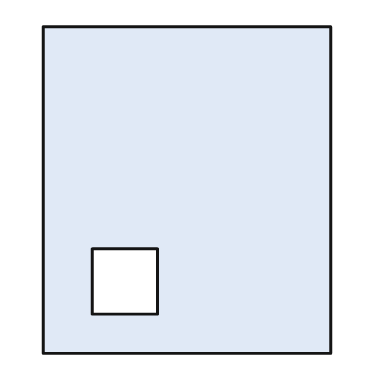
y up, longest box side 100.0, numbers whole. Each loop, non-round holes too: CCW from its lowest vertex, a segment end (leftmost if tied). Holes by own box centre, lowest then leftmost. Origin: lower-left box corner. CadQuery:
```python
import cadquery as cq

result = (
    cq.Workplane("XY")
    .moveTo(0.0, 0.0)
    .lineTo(88.0, 0.0)
    .lineTo(88.0, 100.0)
    .lineTo(0.0, 100.0)
    .close()
    .moveTo(15.0, 12.0)
    .lineTo(35.0, 12.0)
    .lineTo(35.0, 32.0)
    .lineTo(15.0, 32.0)
    .close()
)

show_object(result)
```